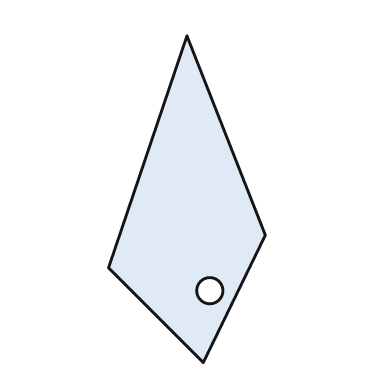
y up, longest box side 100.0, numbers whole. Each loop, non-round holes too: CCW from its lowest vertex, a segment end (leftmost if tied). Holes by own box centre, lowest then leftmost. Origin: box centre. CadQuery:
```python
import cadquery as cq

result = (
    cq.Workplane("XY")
    .moveTo(5.0, -50.0)
    .lineTo(24.0, -11.0)
    .lineTo(0.0, 50.0)
    .lineTo(-24.0, -21.0)
    .close()
    .moveTo(7.0, -28.0)
    .circle(4.0)
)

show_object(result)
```